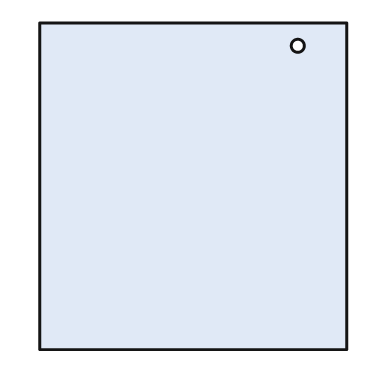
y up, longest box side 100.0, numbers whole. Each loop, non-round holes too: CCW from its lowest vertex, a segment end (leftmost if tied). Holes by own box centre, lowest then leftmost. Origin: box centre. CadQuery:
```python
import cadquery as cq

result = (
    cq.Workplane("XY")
    .moveTo(-47.0, -50.0)
    .lineTo(47.0, -50.0)
    .lineTo(47.0, 50.0)
    .lineTo(-47.0, 50.0)
    .close()
    .moveTo(32.0, 43.0)
    .circle(2.0)
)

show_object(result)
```